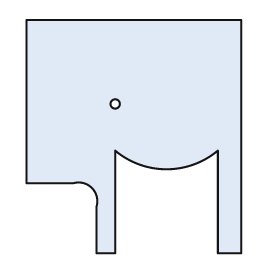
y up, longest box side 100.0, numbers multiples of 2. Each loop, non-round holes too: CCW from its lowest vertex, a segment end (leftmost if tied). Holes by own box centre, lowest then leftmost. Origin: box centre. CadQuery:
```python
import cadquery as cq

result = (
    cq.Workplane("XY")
    .moveTo(-16.0, -50.0)
    .lineTo(-8.0, -50.0)
    .lineTo(-8.0, -6.0)
    .threePointArc((14.0, -14.0), (36.0, -6.0))
    .lineTo(36.0, -50.0)
    .lineTo(46.0, -50.0)
    .lineTo(46.0, 50.0)
    .lineTo(-46.0, 50.0)
    .lineTo(-46.0, -20.0)
    .lineTo(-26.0, -20.0)
    .threePointArc((-18.0, -22.0), (-16.0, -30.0))
    .close()
    .moveTo(-8.0, 14.0)
    .circle(2.0)
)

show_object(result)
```